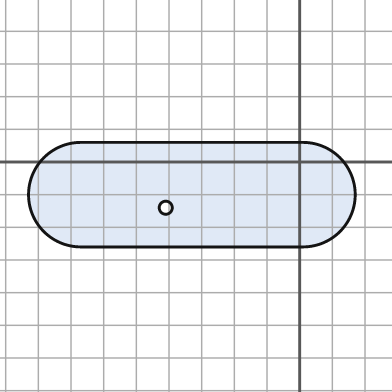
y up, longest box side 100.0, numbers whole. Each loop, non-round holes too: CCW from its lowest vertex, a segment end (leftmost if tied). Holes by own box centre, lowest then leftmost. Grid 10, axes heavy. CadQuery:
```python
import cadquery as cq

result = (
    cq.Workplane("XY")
    .moveTo(-67.0, -26.0)
    .lineTo(1.0, -26.0)
    .threePointArc((17.0, -10.0), (1.0, 6.0))
    .lineTo(-67.0, 6.0)
    .threePointArc((-83.0, -10.0), (-67.0, -26.0))
    .close()
    .moveTo(-41.0, -14.0)
    .circle(2.0)
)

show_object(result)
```